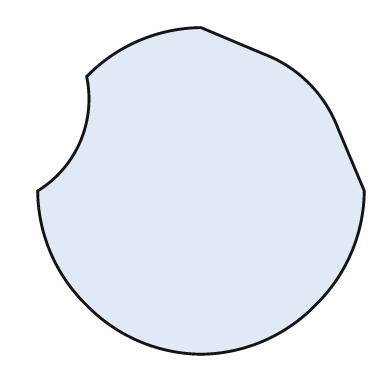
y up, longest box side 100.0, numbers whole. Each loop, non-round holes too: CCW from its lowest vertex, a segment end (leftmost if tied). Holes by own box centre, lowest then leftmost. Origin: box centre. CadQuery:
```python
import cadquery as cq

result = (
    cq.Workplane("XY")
    .moveTo(0.0, -50.0)
    .threePointArc((19.0, -46.0), (35.0, -35.0))
    .threePointArc((46.0, -19.0), (50.0, 0.0))
    .lineTo(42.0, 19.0)
    .threePointArc((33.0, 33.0), (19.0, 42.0))
    .lineTo(0.0, 50.0)
    .threePointArc((-19.0, 46.0), (-35.0, 35.0))
    .threePointArc((-37.0, 15.0), (-50.0, 0.0))
    .threePointArc((-46.0, -19.0), (-35.0, -35.0))
    .threePointArc((-19.0, -46.0), (0.0, -50.0))
    .close()
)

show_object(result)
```